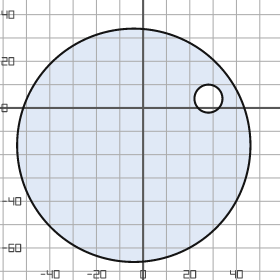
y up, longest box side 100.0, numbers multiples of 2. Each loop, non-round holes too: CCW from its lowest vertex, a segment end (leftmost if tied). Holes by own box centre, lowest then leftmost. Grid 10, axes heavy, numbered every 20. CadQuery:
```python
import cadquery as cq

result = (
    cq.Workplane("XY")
    .moveTo(-4.0, -16.0)
    .circle(50.0)
    .moveTo(28.0, 4.0)
    .circle(6.0)
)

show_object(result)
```